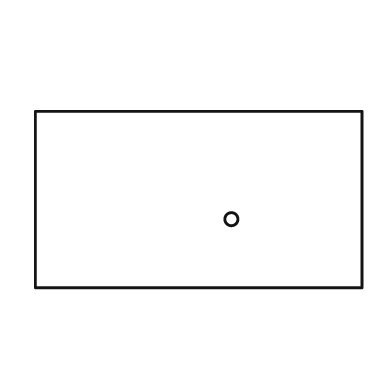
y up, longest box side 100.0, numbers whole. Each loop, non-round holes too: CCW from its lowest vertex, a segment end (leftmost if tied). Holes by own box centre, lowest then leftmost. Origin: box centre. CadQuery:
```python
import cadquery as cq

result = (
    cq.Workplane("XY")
    .moveTo(-50.0, -27.0)
    .lineTo(50.0, -27.0)
    .lineTo(50.0, 27.0)
    .lineTo(-50.0, 27.0)
    .close()
    .moveTo(10.0, -6.0)
    .circle(2.0)
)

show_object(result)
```